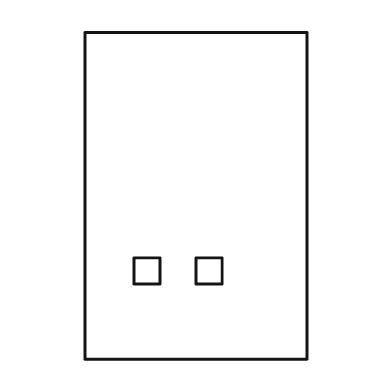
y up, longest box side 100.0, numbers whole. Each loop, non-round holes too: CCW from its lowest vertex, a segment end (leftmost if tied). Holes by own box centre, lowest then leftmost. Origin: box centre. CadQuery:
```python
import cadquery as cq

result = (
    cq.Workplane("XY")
    .moveTo(-34.0, -50.0)
    .lineTo(34.0, -50.0)
    .lineTo(34.0, 50.0)
    .lineTo(-34.0, 50.0)
    .close()
    .moveTo(-19.0, -27.0)
    .lineTo(-11.0, -27.0)
    .lineTo(-11.0, -19.0)
    .lineTo(-19.0, -19.0)
    .close()
    .moveTo(0.0, -27.0)
    .lineTo(8.0, -27.0)
    .lineTo(8.0, -19.0)
    .lineTo(0.0, -19.0)
    .close()
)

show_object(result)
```